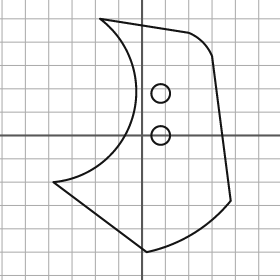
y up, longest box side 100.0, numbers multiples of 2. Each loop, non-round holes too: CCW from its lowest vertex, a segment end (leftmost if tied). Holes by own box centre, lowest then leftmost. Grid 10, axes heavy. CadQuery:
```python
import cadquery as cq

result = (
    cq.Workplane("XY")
    .moveTo(2.0, -50.0)
    .threePointArc((22.0, -42.0), (38.0, -28.0))
    .lineTo(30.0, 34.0)
    .threePointArc((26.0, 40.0), (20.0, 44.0))
    .lineTo(-18.0, 50.0)
    .threePointArc((-4.0, 8.0), (-38.0, -20.0))
    .close()
    .moveTo(8.0, 0.0)
    .circle(4.0)
    .moveTo(8.0, 18.0)
    .circle(4.0)
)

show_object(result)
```